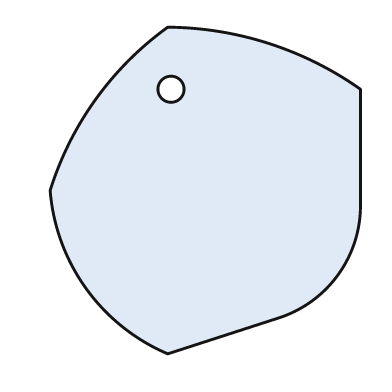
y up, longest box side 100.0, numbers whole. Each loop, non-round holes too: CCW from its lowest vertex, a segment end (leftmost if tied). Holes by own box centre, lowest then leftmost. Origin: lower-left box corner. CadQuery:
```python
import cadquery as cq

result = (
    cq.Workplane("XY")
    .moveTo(36.0, 0.0)
    .lineTo(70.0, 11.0)
    .threePointArc((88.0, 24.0), (95.0, 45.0))
    .lineTo(95.0, 81.0)
    .threePointArc((67.0, 95.0), (36.0, 100.0))
    .threePointArc((14.0, 78.0), (0.0, 50.0))
    .threePointArc((11.0, 20.0), (36.0, 0.0))
    .close()
    .moveTo(37.0, 81.0)
    .circle(4.0)
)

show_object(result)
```